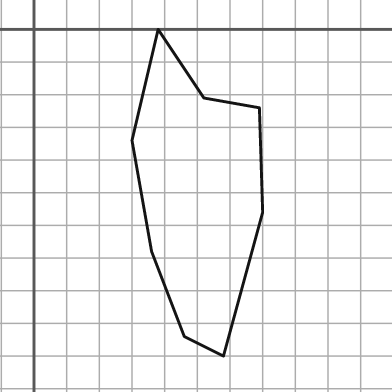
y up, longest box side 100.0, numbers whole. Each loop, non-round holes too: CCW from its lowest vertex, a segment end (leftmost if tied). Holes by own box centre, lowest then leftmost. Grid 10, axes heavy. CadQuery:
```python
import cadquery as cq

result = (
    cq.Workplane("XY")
    .moveTo(58.0, -100.0)
    .lineTo(70.0, -56.0)
    .lineTo(69.0, -24.0)
    .lineTo(52.0, -21.0)
    .lineTo(38.0, 0.0)
    .lineTo(30.0, -34.0)
    .lineTo(36.0, -68.0)
    .lineTo(46.0, -94.0)
    .close()
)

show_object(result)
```